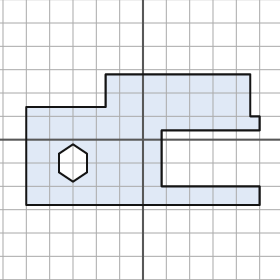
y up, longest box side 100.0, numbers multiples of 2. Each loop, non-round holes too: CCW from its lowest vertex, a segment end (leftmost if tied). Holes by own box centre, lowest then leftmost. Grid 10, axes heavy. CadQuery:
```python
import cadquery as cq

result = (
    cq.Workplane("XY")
    .moveTo(-50.0, -28.0)
    .lineTo(50.0, -28.0)
    .lineTo(50.0, -20.0)
    .lineTo(8.0, -20.0)
    .lineTo(8.0, 4.0)
    .lineTo(50.0, 4.0)
    .lineTo(50.0, 10.0)
    .lineTo(46.0, 10.0)
    .lineTo(46.0, 28.0)
    .lineTo(-16.0, 28.0)
    .lineTo(-16.0, 14.0)
    .lineTo(-50.0, 14.0)
    .close()
    .moveTo(-30.0, -18.0)
    .lineTo(-24.0, -14.0)
    .lineTo(-24.0, -6.0)
    .lineTo(-30.0, -2.0)
    .lineTo(-36.0, -6.0)
    .lineTo(-36.0, -14.0)
    .close()
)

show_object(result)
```